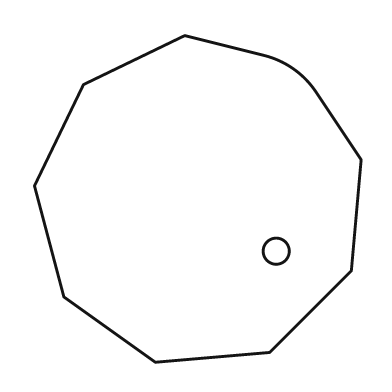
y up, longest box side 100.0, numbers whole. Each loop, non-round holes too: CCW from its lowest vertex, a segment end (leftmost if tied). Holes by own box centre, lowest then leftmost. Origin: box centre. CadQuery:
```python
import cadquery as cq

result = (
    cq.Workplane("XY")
    .moveTo(-13.0, -50.0)
    .lineTo(22.0, -47.0)
    .lineTo(47.0, -22.0)
    .lineTo(50.0, 12.0)
    .lineTo(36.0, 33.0)
    .threePointArc((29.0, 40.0), (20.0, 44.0))
    .lineTo(-4.0, 50.0)
    .lineTo(-35.0, 35.0)
    .lineTo(-50.0, 4.0)
    .lineTo(-41.0, -30.0)
    .close()
    .moveTo(24.0, -16.0)
    .circle(4.0)
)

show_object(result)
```